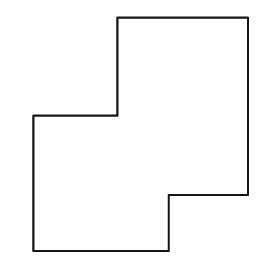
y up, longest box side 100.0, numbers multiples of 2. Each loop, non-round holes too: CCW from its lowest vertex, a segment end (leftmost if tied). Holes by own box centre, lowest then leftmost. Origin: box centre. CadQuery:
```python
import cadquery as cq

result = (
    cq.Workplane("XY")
    .moveTo(-46.0, -50.0)
    .lineTo(12.0, -50.0)
    .lineTo(12.0, -26.0)
    .lineTo(46.0, -26.0)
    .lineTo(46.0, 50.0)
    .lineTo(-10.0, 50.0)
    .lineTo(-10.0, 8.0)
    .lineTo(-46.0, 8.0)
    .close()
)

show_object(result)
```